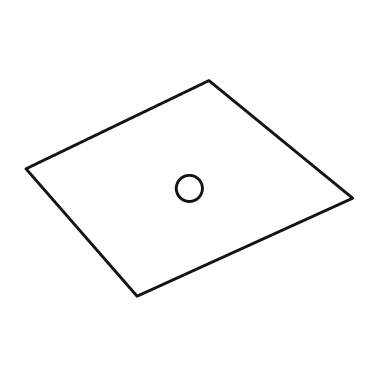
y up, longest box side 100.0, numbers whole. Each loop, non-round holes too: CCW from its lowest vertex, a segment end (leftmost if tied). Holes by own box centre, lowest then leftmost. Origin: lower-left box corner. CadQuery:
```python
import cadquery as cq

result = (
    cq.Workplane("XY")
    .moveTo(34.0, 0.0)
    .lineTo(100.0, 30.0)
    .lineTo(56.0, 66.0)
    .lineTo(0.0, 39.0)
    .close()
    .moveTo(50.0, 33.0)
    .circle(4.0)
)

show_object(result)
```